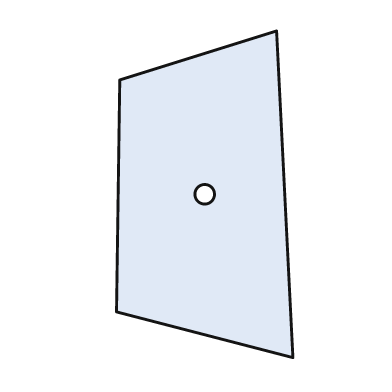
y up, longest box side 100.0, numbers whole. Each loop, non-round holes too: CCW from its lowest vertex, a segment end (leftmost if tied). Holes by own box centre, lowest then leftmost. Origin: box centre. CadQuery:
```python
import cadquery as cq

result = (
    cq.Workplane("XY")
    .moveTo(27.0, -50.0)
    .lineTo(22.0, 50.0)
    .lineTo(-26.0, 35.0)
    .lineTo(-27.0, -36.0)
    .close()
    .moveTo(0.0, 0.0)
    .circle(3.0)
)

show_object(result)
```